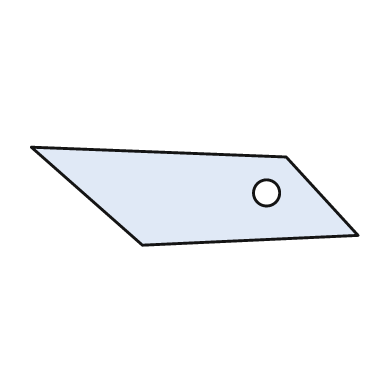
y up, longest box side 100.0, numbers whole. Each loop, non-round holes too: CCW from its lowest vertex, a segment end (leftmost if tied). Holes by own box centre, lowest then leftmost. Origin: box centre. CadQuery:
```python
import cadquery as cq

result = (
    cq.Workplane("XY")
    .moveTo(-16.0, -15.0)
    .lineTo(50.0, -12.0)
    .lineTo(28.0, 12.0)
    .lineTo(-50.0, 15.0)
    .close()
    .moveTo(22.0, 1.0)
    .circle(4.0)
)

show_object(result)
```